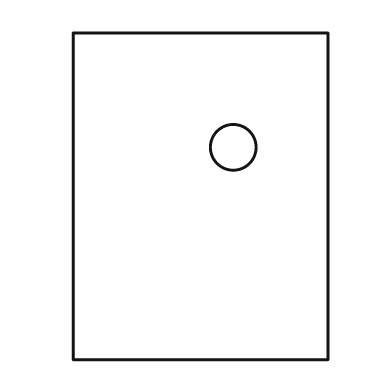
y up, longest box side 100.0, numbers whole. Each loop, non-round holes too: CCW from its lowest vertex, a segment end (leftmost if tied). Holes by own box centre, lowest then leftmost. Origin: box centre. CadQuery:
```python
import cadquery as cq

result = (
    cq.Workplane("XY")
    .moveTo(-39.0, -50.0)
    .lineTo(39.0, -50.0)
    .lineTo(39.0, 50.0)
    .lineTo(-39.0, 50.0)
    .close()
    .moveTo(10.0, 15.0)
    .circle(7.0)
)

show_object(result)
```